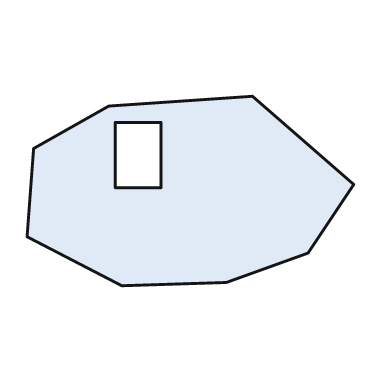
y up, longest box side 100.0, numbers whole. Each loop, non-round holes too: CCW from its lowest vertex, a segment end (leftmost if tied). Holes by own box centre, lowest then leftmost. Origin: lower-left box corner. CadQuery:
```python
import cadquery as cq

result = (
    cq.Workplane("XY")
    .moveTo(29.0, 0.0)
    .lineTo(61.0, 1.0)
    .lineTo(86.0, 10.0)
    .lineTo(100.0, 31.0)
    .lineTo(69.0, 58.0)
    .lineTo(25.0, 55.0)
    .lineTo(2.0, 42.0)
    .lineTo(0.0, 15.0)
    .close()
    .moveTo(27.0, 30.0)
    .lineTo(41.0, 30.0)
    .lineTo(41.0, 50.0)
    .lineTo(27.0, 50.0)
    .close()
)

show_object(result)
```